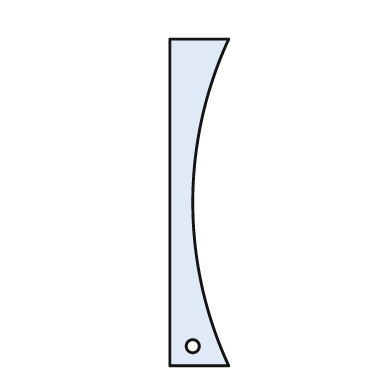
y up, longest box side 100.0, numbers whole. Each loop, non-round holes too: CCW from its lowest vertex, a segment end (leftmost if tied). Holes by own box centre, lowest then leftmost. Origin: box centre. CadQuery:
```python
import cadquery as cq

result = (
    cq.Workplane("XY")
    .moveTo(-9.0, -50.0)
    .lineTo(9.0, -50.0)
    .threePointArc((-2.0, 0.0), (9.0, 50.0))
    .lineTo(-9.0, 50.0)
    .close()
    .moveTo(-2.0, -44.0)
    .circle(2.0)
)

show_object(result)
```